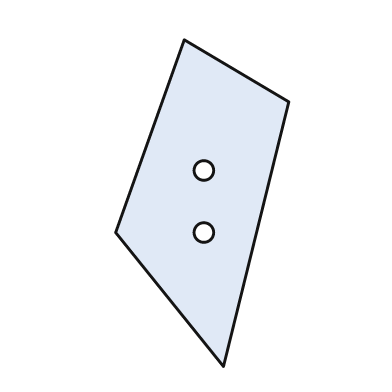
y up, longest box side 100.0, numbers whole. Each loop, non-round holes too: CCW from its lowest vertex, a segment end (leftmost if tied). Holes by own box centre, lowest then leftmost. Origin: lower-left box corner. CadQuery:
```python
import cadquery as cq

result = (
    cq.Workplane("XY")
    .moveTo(33.0, 0.0)
    .lineTo(53.0, 81.0)
    .lineTo(21.0, 100.0)
    .lineTo(0.0, 41.0)
    .close()
    .moveTo(27.0, 41.0)
    .circle(3.0)
    .moveTo(27.0, 60.0)
    .circle(3.0)
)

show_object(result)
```